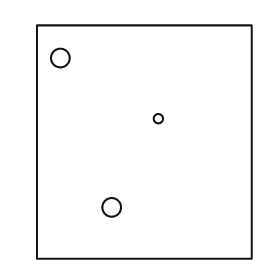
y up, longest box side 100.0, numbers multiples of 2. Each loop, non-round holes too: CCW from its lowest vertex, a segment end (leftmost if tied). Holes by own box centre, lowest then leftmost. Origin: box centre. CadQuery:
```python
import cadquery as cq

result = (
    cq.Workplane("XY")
    .moveTo(-46.0, -50.0)
    .lineTo(46.0, -50.0)
    .lineTo(46.0, 50.0)
    .lineTo(-46.0, 50.0)
    .close()
    .moveTo(-14.0, -28.0)
    .circle(4.0)
    .moveTo(6.0, 10.0)
    .circle(2.0)
    .moveTo(-36.0, 36.0)
    .circle(4.0)
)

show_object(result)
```